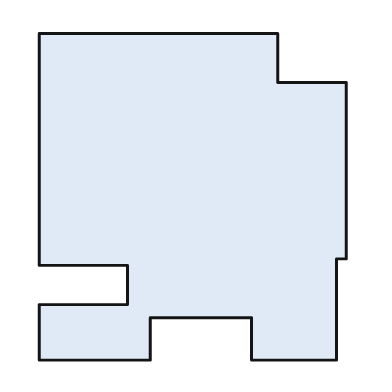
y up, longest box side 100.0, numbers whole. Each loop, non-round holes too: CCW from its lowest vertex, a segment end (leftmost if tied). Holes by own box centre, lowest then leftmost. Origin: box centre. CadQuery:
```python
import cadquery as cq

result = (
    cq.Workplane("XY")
    .moveTo(-47.0, -50.0)
    .lineTo(-13.0, -50.0)
    .lineTo(-13.0, -37.0)
    .lineTo(18.0, -37.0)
    .lineTo(18.0, -50.0)
    .lineTo(44.0, -50.0)
    .lineTo(44.0, -19.0)
    .lineTo(47.0, -19.0)
    .lineTo(47.0, 35.0)
    .lineTo(26.0, 35.0)
    .lineTo(26.0, 50.0)
    .lineTo(-47.0, 50.0)
    .lineTo(-47.0, -21.0)
    .lineTo(-20.0, -21.0)
    .lineTo(-20.0, -33.0)
    .lineTo(-47.0, -33.0)
    .close()
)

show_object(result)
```